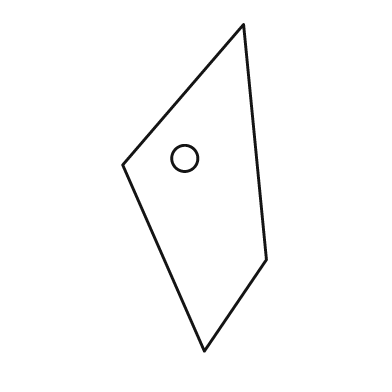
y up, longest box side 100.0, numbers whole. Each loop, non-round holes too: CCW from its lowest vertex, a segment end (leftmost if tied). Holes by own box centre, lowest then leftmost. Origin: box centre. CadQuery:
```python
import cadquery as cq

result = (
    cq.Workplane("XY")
    .moveTo(3.0, -50.0)
    .lineTo(22.0, -22.0)
    .lineTo(15.0, 50.0)
    .lineTo(-22.0, 7.0)
    .close()
    .moveTo(-3.0, 9.0)
    .circle(4.0)
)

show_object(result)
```